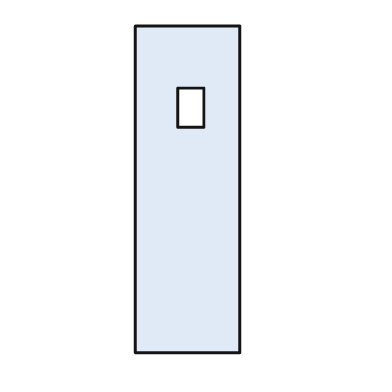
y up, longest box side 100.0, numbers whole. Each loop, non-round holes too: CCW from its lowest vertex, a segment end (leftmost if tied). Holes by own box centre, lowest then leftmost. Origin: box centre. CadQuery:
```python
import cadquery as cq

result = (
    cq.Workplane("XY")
    .moveTo(-16.0, -50.0)
    .lineTo(16.0, -50.0)
    .lineTo(16.0, 50.0)
    .lineTo(-16.0, 50.0)
    .close()
    .moveTo(-3.0, 19.0)
    .lineTo(5.0, 19.0)
    .lineTo(5.0, 31.0)
    .lineTo(-3.0, 31.0)
    .close()
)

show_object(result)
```